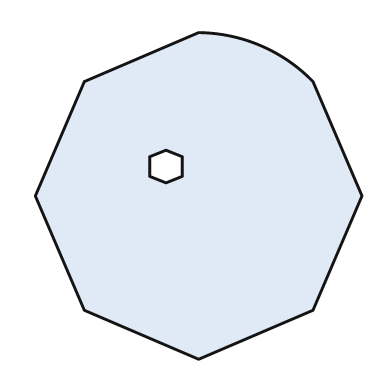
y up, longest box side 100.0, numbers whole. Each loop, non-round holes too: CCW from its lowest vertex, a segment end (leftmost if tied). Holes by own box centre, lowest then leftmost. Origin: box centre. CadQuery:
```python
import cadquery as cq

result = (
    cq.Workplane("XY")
    .moveTo(0.0, -50.0)
    .lineTo(35.0, -35.0)
    .lineTo(50.0, 0.0)
    .lineTo(35.0, 35.0)
    .threePointArc((19.0, 46.0), (0.0, 50.0))
    .lineTo(-35.0, 35.0)
    .lineTo(-50.0, 0.0)
    .lineTo(-35.0, -35.0)
    .close()
    .moveTo(-10.0, 4.0)
    .lineTo(-5.0, 6.0)
    .lineTo(-5.0, 12.0)
    .lineTo(-10.0, 14.0)
    .lineTo(-15.0, 12.0)
    .lineTo(-15.0, 6.0)
    .close()
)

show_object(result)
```